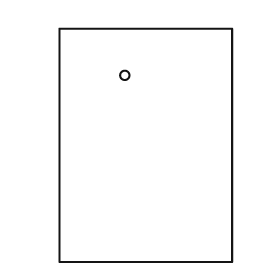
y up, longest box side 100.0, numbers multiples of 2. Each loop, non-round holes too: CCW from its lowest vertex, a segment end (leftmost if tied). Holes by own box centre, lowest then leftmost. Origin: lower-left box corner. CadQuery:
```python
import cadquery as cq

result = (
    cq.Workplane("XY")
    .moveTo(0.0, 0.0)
    .lineTo(74.0, 0.0)
    .lineTo(74.0, 100.0)
    .lineTo(0.0, 100.0)
    .close()
    .moveTo(28.0, 80.0)
    .circle(2.0)
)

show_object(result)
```